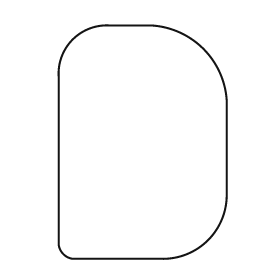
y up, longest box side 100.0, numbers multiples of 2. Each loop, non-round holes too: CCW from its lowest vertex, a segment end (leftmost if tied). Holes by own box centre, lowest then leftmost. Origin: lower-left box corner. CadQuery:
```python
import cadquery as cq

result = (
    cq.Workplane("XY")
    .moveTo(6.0, 0.0)
    .lineTo(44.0, 0.0)
    .threePointArc((64.0, 8.0), (72.0, 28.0))
    .lineTo(72.0, 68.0)
    .threePointArc((62.0, 90.0), (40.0, 100.0))
    .lineTo(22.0, 100.0)
    .threePointArc((6.0, 94.0), (0.0, 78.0))
    .lineTo(0.0, 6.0)
    .threePointArc((2.0, 2.0), (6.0, 0.0))
    .close()
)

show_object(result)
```